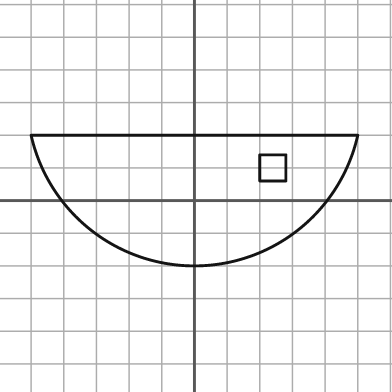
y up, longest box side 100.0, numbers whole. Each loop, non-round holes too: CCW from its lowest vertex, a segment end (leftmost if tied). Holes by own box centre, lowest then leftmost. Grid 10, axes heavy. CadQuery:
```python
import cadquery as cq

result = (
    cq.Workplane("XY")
    .moveTo(-50.0, 20.0)
    .threePointArc((0.0, -20.0), (50.0, 20.0))
    .close()
    .moveTo(20.0, 6.0)
    .lineTo(28.0, 6.0)
    .lineTo(28.0, 14.0)
    .lineTo(20.0, 14.0)
    .close()
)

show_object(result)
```